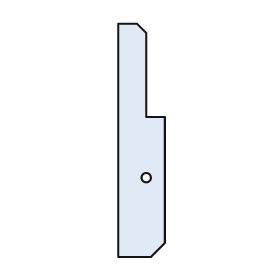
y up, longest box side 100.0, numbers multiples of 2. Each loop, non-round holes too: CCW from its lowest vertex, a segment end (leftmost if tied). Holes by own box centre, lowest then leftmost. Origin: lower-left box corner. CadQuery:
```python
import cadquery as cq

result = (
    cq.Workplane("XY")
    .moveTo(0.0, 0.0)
    .lineTo(14.0, 0.0)
    .lineTo(20.0, 6.0)
    .lineTo(20.0, 60.0)
    .lineTo(12.0, 60.0)
    .lineTo(12.0, 96.0)
    .lineTo(8.0, 100.0)
    .lineTo(0.0, 100.0)
    .close()
    .moveTo(12.0, 34.0)
    .circle(2.0)
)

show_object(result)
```